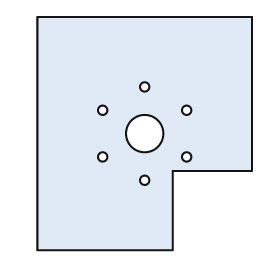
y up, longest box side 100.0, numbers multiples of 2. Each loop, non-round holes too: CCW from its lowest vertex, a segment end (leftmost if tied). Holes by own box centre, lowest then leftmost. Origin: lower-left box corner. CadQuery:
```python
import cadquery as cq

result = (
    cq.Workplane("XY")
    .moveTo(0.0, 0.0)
    .lineTo(58.0, 0.0)
    .lineTo(58.0, 34.0)
    .lineTo(92.0, 34.0)
    .lineTo(92.0, 100.0)
    .lineTo(0.0, 100.0)
    .close()
    .moveTo(46.0, 30.0)
    .circle(2.0)
    .moveTo(28.0, 40.0)
    .circle(2.0)
    .moveTo(64.0, 40.0)
    .circle(2.0)
    .moveTo(46.0, 50.0)
    .circle(8.0)
    .moveTo(28.0, 60.0)
    .circle(2.0)
    .moveTo(64.0, 60.0)
    .circle(2.0)
    .moveTo(46.0, 70.0)
    .circle(2.0)
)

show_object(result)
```